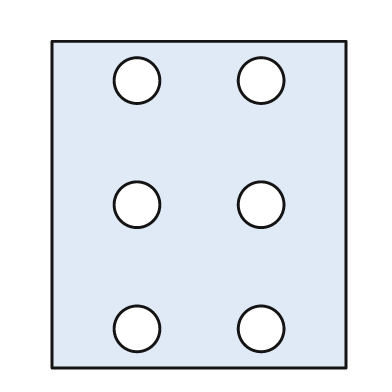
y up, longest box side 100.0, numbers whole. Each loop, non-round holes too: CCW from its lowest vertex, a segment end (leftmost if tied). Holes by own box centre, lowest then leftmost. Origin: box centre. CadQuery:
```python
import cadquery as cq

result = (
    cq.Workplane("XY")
    .moveTo(-45.0, -50.0)
    .lineTo(45.0, -50.0)
    .lineTo(45.0, 50.0)
    .lineTo(-45.0, 50.0)
    .close()
    .moveTo(-19.0, -38.0)
    .circle(7.0)
    .moveTo(19.0, -38.0)
    .circle(7.0)
    .moveTo(-19.0, 0.0)
    .circle(7.0)
    .moveTo(19.0, 0.0)
    .circle(7.0)
    .moveTo(-19.0, 38.0)
    .circle(7.0)
    .moveTo(19.0, 38.0)
    .circle(7.0)
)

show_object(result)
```